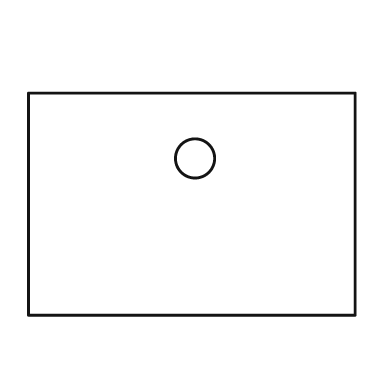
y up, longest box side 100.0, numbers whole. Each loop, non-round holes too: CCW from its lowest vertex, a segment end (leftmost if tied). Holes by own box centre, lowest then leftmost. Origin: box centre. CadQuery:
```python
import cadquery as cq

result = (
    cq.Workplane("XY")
    .moveTo(-50.0, -34.0)
    .lineTo(50.0, -34.0)
    .lineTo(50.0, 34.0)
    .lineTo(-50.0, 34.0)
    .close()
    .moveTo(1.0, 14.0)
    .circle(6.0)
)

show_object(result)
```